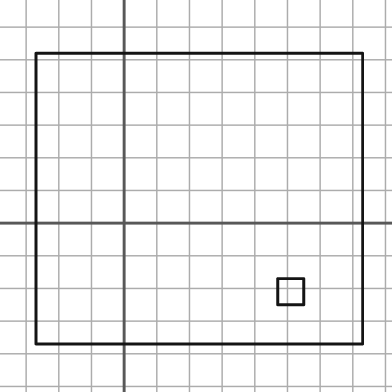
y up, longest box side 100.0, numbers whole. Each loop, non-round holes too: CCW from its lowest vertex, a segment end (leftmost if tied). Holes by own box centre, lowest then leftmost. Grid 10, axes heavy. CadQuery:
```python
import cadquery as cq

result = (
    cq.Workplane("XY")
    .moveTo(-27.0, -37.0)
    .lineTo(73.0, -37.0)
    .lineTo(73.0, 52.0)
    .lineTo(-27.0, 52.0)
    .close()
    .moveTo(47.0, -25.0)
    .lineTo(55.0, -25.0)
    .lineTo(55.0, -17.0)
    .lineTo(47.0, -17.0)
    .close()
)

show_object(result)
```